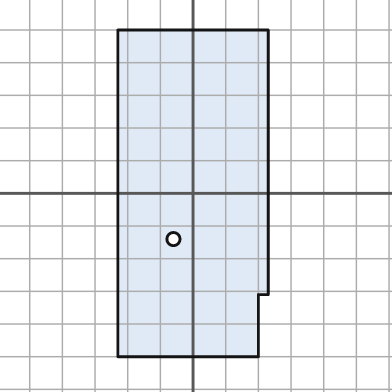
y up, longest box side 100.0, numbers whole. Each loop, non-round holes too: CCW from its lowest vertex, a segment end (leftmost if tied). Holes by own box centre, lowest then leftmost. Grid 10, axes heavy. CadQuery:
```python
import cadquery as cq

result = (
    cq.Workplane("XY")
    .moveTo(-23.0, -50.0)
    .lineTo(20.0, -50.0)
    .lineTo(20.0, -31.0)
    .lineTo(23.0, -31.0)
    .lineTo(23.0, 50.0)
    .lineTo(-23.0, 50.0)
    .close()
    .moveTo(-6.0, -14.0)
    .circle(2.0)
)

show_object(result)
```